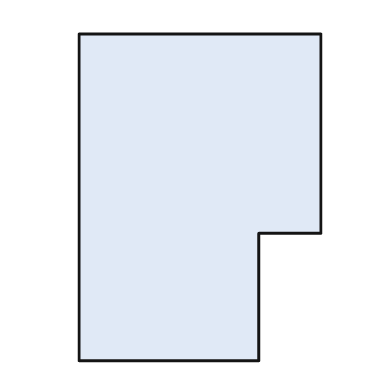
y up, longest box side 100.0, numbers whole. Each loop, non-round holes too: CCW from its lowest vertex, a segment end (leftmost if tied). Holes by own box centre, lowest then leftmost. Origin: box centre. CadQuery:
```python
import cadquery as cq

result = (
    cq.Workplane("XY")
    .moveTo(-37.0, -50.0)
    .lineTo(18.0, -50.0)
    .lineTo(18.0, -11.0)
    .lineTo(37.0, -11.0)
    .lineTo(37.0, 50.0)
    .lineTo(-37.0, 50.0)
    .close()
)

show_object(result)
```